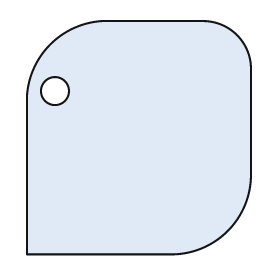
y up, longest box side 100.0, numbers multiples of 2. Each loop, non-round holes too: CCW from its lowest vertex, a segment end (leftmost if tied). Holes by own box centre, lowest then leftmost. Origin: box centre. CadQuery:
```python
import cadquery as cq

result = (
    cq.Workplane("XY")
    .moveTo(-48.0, -50.0)
    .lineTo(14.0, -50.0)
    .threePointArc((38.0, -40.0), (48.0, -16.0))
    .lineTo(48.0, 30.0)
    .threePointArc((42.0, 44.0), (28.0, 50.0))
    .lineTo(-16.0, 50.0)
    .threePointArc((-38.0, 40.0), (-48.0, 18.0))
    .close()
    .moveTo(-36.0, 20.0)
    .circle(6.0)
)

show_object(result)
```